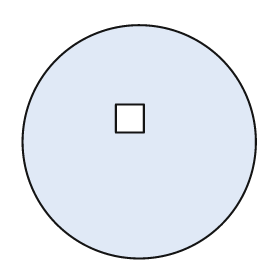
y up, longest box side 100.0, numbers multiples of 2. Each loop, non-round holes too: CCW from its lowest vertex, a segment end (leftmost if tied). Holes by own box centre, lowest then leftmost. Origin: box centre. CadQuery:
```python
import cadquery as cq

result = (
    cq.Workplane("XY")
    .moveTo(0.0, 0.0)
    .circle(50.0)
    .moveTo(-10.0, 4.0)
    .lineTo(2.0, 4.0)
    .lineTo(2.0, 16.0)
    .lineTo(-10.0, 16.0)
    .close()
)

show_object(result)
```